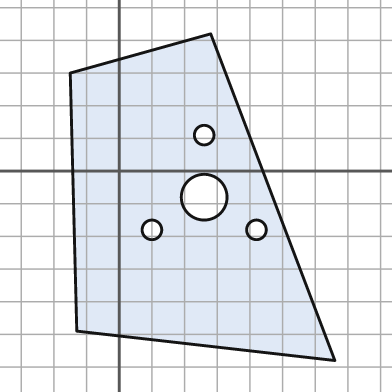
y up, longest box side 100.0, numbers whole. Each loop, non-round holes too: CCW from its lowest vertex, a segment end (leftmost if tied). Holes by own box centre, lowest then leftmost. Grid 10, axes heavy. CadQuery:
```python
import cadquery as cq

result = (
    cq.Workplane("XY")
    .moveTo(66.0, -58.0)
    .lineTo(28.0, 42.0)
    .lineTo(-15.0, 30.0)
    .lineTo(-13.0, -49.0)
    .close()
    .moveTo(10.0, -18.0)
    .circle(3.0)
    .moveTo(42.0, -18.0)
    .circle(3.0)
    .moveTo(26.0, -8.0)
    .circle(7.0)
    .moveTo(26.0, 11.0)
    .circle(3.0)
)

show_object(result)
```